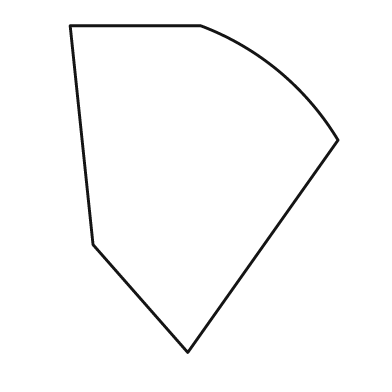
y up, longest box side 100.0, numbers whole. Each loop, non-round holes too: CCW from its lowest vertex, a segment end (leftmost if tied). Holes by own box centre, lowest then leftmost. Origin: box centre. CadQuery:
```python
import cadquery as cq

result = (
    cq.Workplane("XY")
    .moveTo(-5.0, -50.0)
    .lineTo(41.0, 15.0)
    .threePointArc((23.0, 36.0), (-1.0, 50.0))
    .lineTo(-41.0, 50.0)
    .lineTo(-34.0, -17.0)
    .close()
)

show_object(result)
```